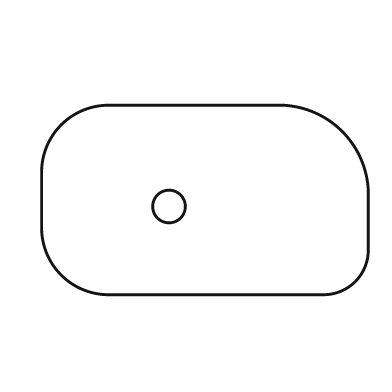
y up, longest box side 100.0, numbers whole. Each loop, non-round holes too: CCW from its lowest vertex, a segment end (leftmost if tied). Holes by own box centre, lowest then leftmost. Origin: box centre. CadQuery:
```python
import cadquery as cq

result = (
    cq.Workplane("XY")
    .moveTo(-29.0, -29.0)
    .lineTo(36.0, -29.0)
    .threePointArc((46.0, -25.0), (50.0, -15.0))
    .lineTo(50.0, 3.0)
    .threePointArc((42.0, 21.0), (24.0, 29.0))
    .lineTo(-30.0, 29.0)
    .threePointArc((-44.0, 23.0), (-50.0, 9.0))
    .lineTo(-50.0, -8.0)
    .threePointArc((-44.0, -23.0), (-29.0, -29.0))
    .close()
    .moveTo(-11.0, -2.0)
    .circle(5.0)
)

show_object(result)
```